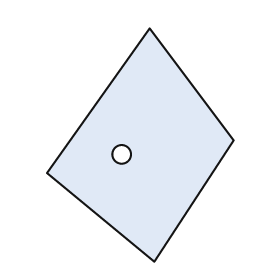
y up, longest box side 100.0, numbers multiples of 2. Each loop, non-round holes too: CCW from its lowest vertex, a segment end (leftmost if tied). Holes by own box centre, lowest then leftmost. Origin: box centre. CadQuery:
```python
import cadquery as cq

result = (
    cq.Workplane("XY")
    .moveTo(6.0, -50.0)
    .lineTo(40.0, 2.0)
    .lineTo(4.0, 50.0)
    .lineTo(-40.0, -12.0)
    .close()
    .moveTo(-8.0, -4.0)
    .circle(4.0)
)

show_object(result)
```